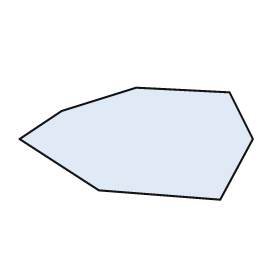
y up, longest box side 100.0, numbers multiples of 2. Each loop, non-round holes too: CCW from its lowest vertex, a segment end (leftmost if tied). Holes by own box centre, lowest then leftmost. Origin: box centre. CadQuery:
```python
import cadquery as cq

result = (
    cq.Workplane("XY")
    .moveTo(36.0, -24.0)
    .lineTo(50.0, 2.0)
    .lineTo(40.0, 22.0)
    .lineTo(0.0, 24.0)
    .lineTo(-32.0, 14.0)
    .lineTo(-50.0, 2.0)
    .lineTo(-16.0, -20.0)
    .close()
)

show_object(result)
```